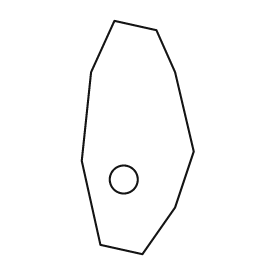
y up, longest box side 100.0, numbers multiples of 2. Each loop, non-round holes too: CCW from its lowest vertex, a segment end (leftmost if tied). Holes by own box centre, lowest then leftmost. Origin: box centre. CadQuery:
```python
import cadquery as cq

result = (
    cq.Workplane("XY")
    .moveTo(2.0, -50.0)
    .lineTo(16.0, -30.0)
    .lineTo(24.0, -6.0)
    .lineTo(16.0, 28.0)
    .lineTo(8.0, 46.0)
    .lineTo(-10.0, 50.0)
    .lineTo(-20.0, 28.0)
    .lineTo(-24.0, -10.0)
    .lineTo(-16.0, -46.0)
    .close()
    .moveTo(-6.0, -18.0)
    .circle(6.0)
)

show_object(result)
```